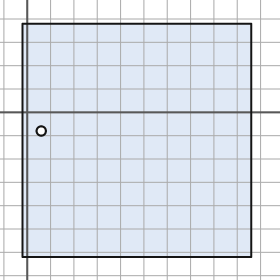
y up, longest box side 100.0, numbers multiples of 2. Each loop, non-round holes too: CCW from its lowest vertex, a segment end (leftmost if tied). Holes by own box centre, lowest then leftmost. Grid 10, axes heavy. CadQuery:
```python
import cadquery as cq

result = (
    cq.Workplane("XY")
    .moveTo(-2.0, -62.0)
    .lineTo(96.0, -62.0)
    .lineTo(96.0, 38.0)
    .lineTo(-2.0, 38.0)
    .close()
    .moveTo(6.0, -8.0)
    .circle(2.0)
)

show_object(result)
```